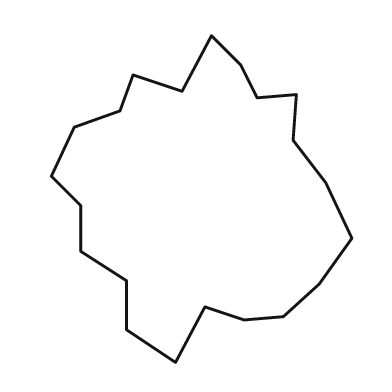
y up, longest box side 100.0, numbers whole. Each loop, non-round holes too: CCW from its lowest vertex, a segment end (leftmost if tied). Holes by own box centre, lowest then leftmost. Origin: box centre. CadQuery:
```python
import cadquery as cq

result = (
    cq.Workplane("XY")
    .moveTo(-8.0, -50.0)
    .lineTo(1.0, -33.0)
    .lineTo(13.0, -37.0)
    .lineTo(25.0, -36.0)
    .lineTo(36.0, -26.0)
    .lineTo(46.0, -12.0)
    .lineTo(38.0, 5.0)
    .lineTo(28.0, 18.0)
    .lineTo(29.0, 32.0)
    .lineTo(17.0, 31.0)
    .lineTo(12.0, 41.0)
    .lineTo(3.0, 50.0)
    .lineTo(-6.0, 33.0)
    .lineTo(-21.0, 38.0)
    .lineTo(-25.0, 27.0)
    .lineTo(-39.0, 22.0)
    .lineTo(-46.0, 7.0)
    .lineTo(-37.0, -2.0)
    .lineTo(-37.0, -16.0)
    .lineTo(-23.0, -25.0)
    .lineTo(-23.0, -40.0)
    .close()
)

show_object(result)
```